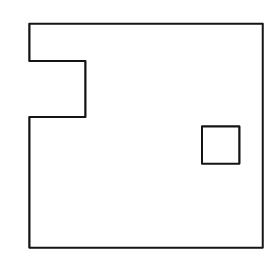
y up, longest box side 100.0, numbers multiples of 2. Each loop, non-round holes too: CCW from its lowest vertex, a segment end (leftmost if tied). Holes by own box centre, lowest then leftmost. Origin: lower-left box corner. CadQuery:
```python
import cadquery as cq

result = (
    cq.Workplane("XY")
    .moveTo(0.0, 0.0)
    .lineTo(100.0, 0.0)
    .lineTo(100.0, 96.0)
    .lineTo(0.0, 96.0)
    .lineTo(0.0, 80.0)
    .lineTo(24.0, 80.0)
    .lineTo(24.0, 56.0)
    .lineTo(0.0, 56.0)
    .close()
    .moveTo(74.0, 36.0)
    .lineTo(90.0, 36.0)
    .lineTo(90.0, 52.0)
    .lineTo(74.0, 52.0)
    .close()
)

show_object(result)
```